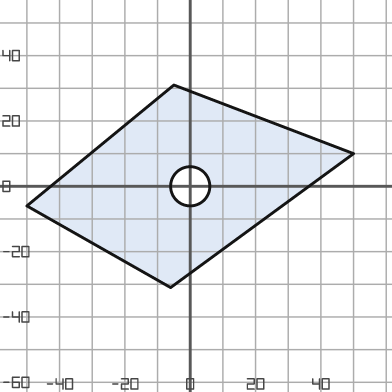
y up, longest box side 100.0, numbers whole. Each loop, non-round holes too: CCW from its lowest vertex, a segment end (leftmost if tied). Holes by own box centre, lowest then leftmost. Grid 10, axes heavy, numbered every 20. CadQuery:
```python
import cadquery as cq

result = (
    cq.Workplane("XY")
    .moveTo(-6.0, -31.0)
    .lineTo(50.0, 10.0)
    .lineTo(-5.0, 31.0)
    .lineTo(-50.0, -6.0)
    .close()
    .moveTo(0.0, 0.0)
    .circle(6.0)
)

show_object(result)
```